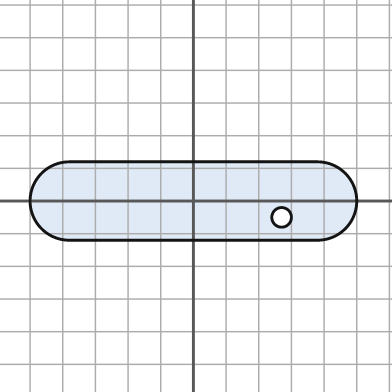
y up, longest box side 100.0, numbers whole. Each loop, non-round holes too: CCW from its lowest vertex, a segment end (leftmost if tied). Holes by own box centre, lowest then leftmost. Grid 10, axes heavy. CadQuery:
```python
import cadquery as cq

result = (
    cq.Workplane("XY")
    .moveTo(-38.0, -12.0)
    .lineTo(38.0, -12.0)
    .threePointArc((50.0, 0.0), (38.0, 12.0))
    .lineTo(-38.0, 12.0)
    .threePointArc((-50.0, 0.0), (-38.0, -12.0))
    .close()
    .moveTo(27.0, -5.0)
    .circle(3.0)
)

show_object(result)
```